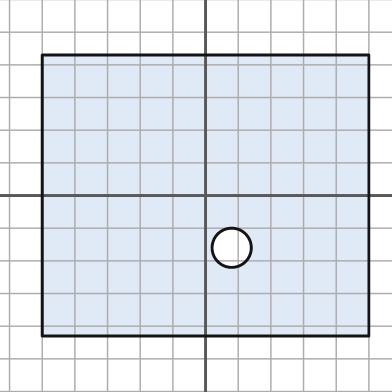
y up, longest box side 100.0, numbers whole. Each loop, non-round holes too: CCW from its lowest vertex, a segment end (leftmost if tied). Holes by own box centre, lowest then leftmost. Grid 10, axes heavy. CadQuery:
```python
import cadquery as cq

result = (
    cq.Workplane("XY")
    .moveTo(-50.0, -43.0)
    .lineTo(50.0, -43.0)
    .lineTo(50.0, 43.0)
    .lineTo(-50.0, 43.0)
    .close()
    .moveTo(8.0, -16.0)
    .circle(6.0)
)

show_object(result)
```